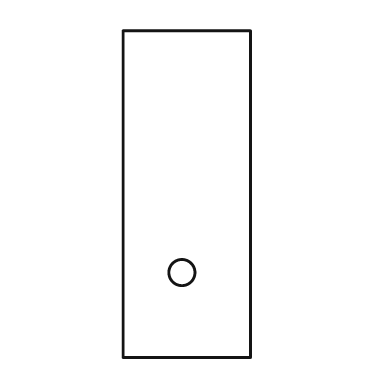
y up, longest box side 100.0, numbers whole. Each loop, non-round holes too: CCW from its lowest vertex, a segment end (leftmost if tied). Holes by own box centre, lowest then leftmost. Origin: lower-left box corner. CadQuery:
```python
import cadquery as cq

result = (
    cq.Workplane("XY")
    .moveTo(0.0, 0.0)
    .lineTo(39.0, 0.0)
    .lineTo(39.0, 100.0)
    .lineTo(0.0, 100.0)
    .close()
    .moveTo(18.0, 26.0)
    .circle(4.0)
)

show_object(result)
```